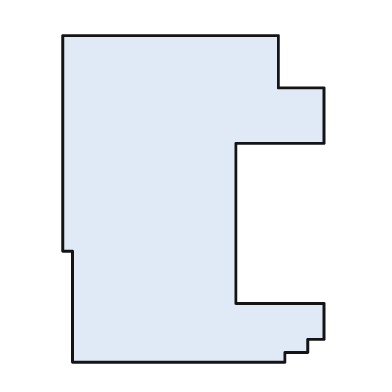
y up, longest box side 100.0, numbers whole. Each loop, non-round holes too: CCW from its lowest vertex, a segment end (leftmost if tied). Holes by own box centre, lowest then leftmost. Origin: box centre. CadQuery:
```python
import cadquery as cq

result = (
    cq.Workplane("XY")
    .moveTo(-37.0, -50.0)
    .lineTo(28.0, -50.0)
    .lineTo(28.0, -47.0)
    .lineTo(35.0, -47.0)
    .lineTo(35.0, -43.0)
    .lineTo(40.0, -43.0)
    .lineTo(40.0, -32.0)
    .lineTo(13.0, -32.0)
    .lineTo(13.0, 17.0)
    .lineTo(40.0, 17.0)
    .lineTo(40.0, 34.0)
    .lineTo(26.0, 34.0)
    .lineTo(26.0, 50.0)
    .lineTo(-40.0, 50.0)
    .lineTo(-40.0, -16.0)
    .lineTo(-37.0, -16.0)
    .close()
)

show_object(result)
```